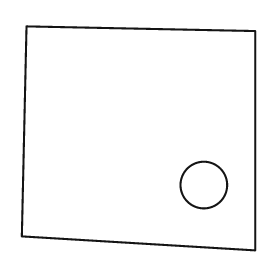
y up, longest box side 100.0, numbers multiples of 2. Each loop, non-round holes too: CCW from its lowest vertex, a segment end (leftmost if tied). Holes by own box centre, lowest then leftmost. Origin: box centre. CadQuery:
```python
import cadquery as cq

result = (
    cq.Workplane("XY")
    .moveTo(50.0, -48.0)
    .lineTo(50.0, 46.0)
    .lineTo(-48.0, 48.0)
    .lineTo(-50.0, -42.0)
    .close()
    .moveTo(28.0, -20.0)
    .circle(10.0)
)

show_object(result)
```